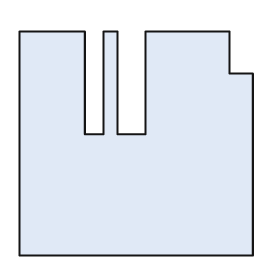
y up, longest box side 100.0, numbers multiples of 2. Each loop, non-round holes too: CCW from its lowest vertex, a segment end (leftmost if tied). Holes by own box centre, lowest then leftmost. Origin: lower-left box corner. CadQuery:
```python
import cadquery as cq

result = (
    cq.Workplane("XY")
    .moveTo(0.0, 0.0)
    .lineTo(100.0, 0.0)
    .lineTo(100.0, 78.0)
    .lineTo(90.0, 78.0)
    .lineTo(90.0, 96.0)
    .lineTo(54.0, 96.0)
    .lineTo(54.0, 52.0)
    .lineTo(42.0, 52.0)
    .lineTo(42.0, 96.0)
    .lineTo(36.0, 96.0)
    .lineTo(36.0, 52.0)
    .lineTo(28.0, 52.0)
    .lineTo(28.0, 96.0)
    .lineTo(0.0, 96.0)
    .close()
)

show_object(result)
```